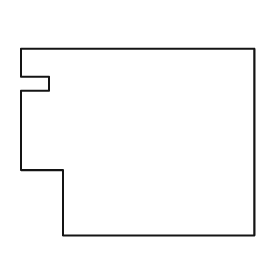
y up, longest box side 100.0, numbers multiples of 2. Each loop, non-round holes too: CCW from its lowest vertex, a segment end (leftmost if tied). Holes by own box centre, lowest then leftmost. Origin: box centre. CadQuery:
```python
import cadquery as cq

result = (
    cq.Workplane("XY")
    .moveTo(-32.0, -40.0)
    .lineTo(50.0, -40.0)
    .lineTo(50.0, 40.0)
    .lineTo(-50.0, 40.0)
    .lineTo(-50.0, 28.0)
    .lineTo(-38.0, 28.0)
    .lineTo(-38.0, 22.0)
    .lineTo(-50.0, 22.0)
    .lineTo(-50.0, -12.0)
    .lineTo(-32.0, -12.0)
    .close()
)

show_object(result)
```